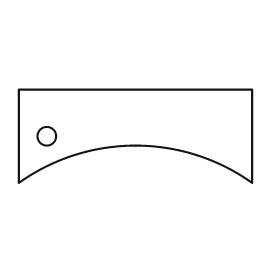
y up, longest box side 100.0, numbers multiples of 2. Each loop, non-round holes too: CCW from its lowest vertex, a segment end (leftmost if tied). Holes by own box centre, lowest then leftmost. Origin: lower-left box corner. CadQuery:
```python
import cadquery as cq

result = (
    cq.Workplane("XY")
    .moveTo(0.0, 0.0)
    .threePointArc((50.0, 16.0), (100.0, 0.0))
    .lineTo(100.0, 40.0)
    .lineTo(0.0, 40.0)
    .close()
    .moveTo(12.0, 20.0)
    .circle(4.0)
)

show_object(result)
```